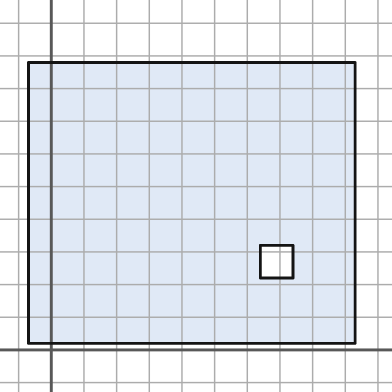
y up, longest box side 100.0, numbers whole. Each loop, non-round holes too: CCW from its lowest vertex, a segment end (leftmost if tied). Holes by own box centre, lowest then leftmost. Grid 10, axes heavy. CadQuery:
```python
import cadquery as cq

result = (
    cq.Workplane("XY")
    .moveTo(-7.0, 2.0)
    .lineTo(93.0, 2.0)
    .lineTo(93.0, 88.0)
    .lineTo(-7.0, 88.0)
    .close()
    .moveTo(64.0, 22.0)
    .lineTo(74.0, 22.0)
    .lineTo(74.0, 32.0)
    .lineTo(64.0, 32.0)
    .close()
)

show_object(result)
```